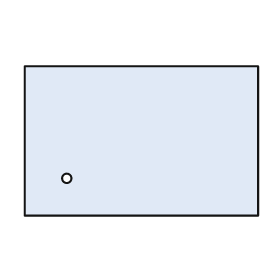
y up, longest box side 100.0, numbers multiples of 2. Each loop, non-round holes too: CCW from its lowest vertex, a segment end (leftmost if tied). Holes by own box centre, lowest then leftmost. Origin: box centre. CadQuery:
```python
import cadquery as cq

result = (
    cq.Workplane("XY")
    .moveTo(-50.0, -32.0)
    .lineTo(50.0, -32.0)
    .lineTo(50.0, 32.0)
    .lineTo(-50.0, 32.0)
    .close()
    .moveTo(-32.0, -16.0)
    .circle(2.0)
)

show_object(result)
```